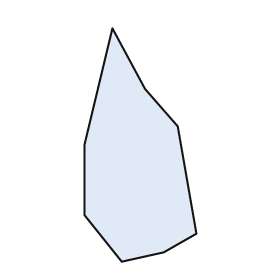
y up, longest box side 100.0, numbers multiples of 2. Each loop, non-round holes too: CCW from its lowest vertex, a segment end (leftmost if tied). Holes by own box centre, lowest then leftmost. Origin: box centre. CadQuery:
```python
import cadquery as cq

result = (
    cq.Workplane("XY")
    .moveTo(-8.0, -50.0)
    .lineTo(10.0, -46.0)
    .lineTo(24.0, -38.0)
    .lineTo(16.0, 8.0)
    .lineTo(2.0, 24.0)
    .lineTo(-12.0, 50.0)
    .lineTo(-24.0, 0.0)
    .lineTo(-24.0, -30.0)
    .close()
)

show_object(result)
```